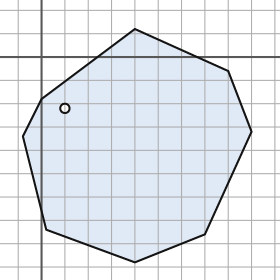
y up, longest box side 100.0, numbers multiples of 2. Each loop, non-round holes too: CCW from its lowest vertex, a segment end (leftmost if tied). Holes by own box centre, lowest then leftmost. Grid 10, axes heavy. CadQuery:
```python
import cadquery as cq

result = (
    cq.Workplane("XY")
    .moveTo(40.0, -88.0)
    .lineTo(70.0, -76.0)
    .lineTo(90.0, -32.0)
    .lineTo(80.0, -6.0)
    .lineTo(40.0, 12.0)
    .lineTo(0.0, -18.0)
    .lineTo(-8.0, -34.0)
    .lineTo(2.0, -74.0)
    .close()
    .moveTo(10.0, -22.0)
    .circle(2.0)
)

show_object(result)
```